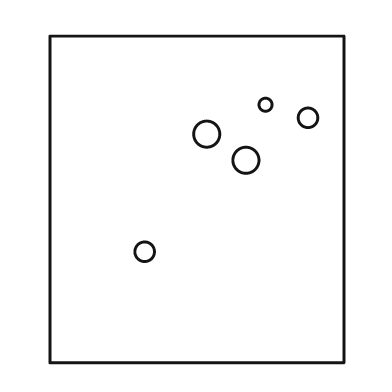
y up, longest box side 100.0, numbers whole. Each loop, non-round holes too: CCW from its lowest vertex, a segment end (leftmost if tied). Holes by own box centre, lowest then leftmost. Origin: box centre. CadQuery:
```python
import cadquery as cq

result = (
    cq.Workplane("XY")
    .moveTo(-45.0, -50.0)
    .lineTo(45.0, -50.0)
    .lineTo(45.0, 50.0)
    .lineTo(-45.0, 50.0)
    .close()
    .moveTo(-16.0, -16.0)
    .circle(3.0)
    .moveTo(15.0, 12.0)
    .circle(4.0)
    .moveTo(3.0, 20.0)
    .circle(4.0)
    .moveTo(34.0, 25.0)
    .circle(3.0)
    .moveTo(21.0, 29.0)
    .circle(2.0)
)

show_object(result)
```